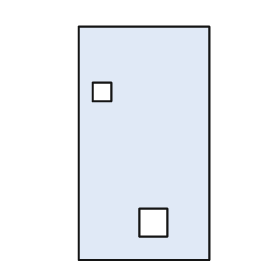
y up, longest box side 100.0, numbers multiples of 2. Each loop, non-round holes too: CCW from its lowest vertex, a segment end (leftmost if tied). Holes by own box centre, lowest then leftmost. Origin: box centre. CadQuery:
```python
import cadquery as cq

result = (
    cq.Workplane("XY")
    .moveTo(-28.0, -50.0)
    .lineTo(28.0, -50.0)
    .lineTo(28.0, 50.0)
    .lineTo(-28.0, 50.0)
    .close()
    .moveTo(-2.0, -40.0)
    .lineTo(10.0, -40.0)
    .lineTo(10.0, -28.0)
    .lineTo(-2.0, -28.0)
    .close()
    .moveTo(-22.0, 18.0)
    .lineTo(-14.0, 18.0)
    .lineTo(-14.0, 26.0)
    .lineTo(-22.0, 26.0)
    .close()
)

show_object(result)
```